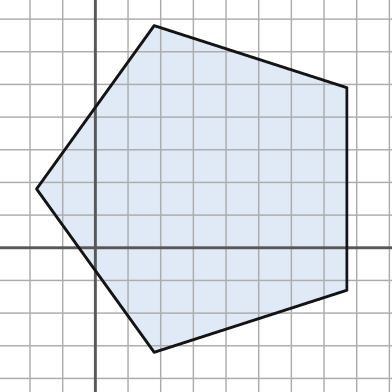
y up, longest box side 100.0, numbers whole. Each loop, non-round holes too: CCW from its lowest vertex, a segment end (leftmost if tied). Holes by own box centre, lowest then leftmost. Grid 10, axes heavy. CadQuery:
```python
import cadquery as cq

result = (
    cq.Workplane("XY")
    .moveTo(18.0, -32.0)
    .lineTo(77.0, -13.0)
    .lineTo(77.0, 49.0)
    .lineTo(18.0, 68.0)
    .lineTo(-18.0, 18.0)
    .close()
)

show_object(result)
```